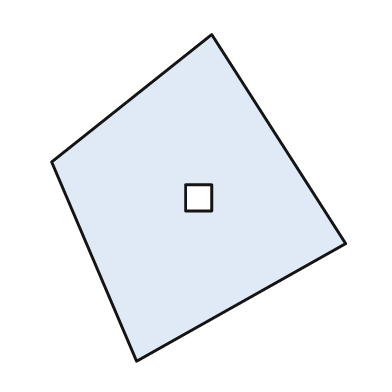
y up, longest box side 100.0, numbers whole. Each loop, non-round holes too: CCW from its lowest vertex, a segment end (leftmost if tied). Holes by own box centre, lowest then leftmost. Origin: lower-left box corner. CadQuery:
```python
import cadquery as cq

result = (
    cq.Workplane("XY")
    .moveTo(26.0, 0.0)
    .lineTo(90.0, 36.0)
    .lineTo(49.0, 100.0)
    .lineTo(0.0, 61.0)
    .close()
    .moveTo(41.0, 46.0)
    .lineTo(49.0, 46.0)
    .lineTo(49.0, 54.0)
    .lineTo(41.0, 54.0)
    .close()
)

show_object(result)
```